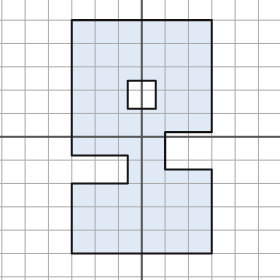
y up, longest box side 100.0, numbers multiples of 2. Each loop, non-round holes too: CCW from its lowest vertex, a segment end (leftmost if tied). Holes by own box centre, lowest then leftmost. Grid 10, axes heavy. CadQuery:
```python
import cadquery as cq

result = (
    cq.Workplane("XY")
    .moveTo(-30.0, -50.0)
    .lineTo(30.0, -50.0)
    .lineTo(30.0, -14.0)
    .lineTo(10.0, -14.0)
    .lineTo(10.0, 2.0)
    .lineTo(30.0, 2.0)
    .lineTo(30.0, 50.0)
    .lineTo(-30.0, 50.0)
    .lineTo(-30.0, -8.0)
    .lineTo(-6.0, -8.0)
    .lineTo(-6.0, -20.0)
    .lineTo(-30.0, -20.0)
    .close()
    .moveTo(-6.0, 12.0)
    .lineTo(6.0, 12.0)
    .lineTo(6.0, 24.0)
    .lineTo(-6.0, 24.0)
    .close()
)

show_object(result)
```